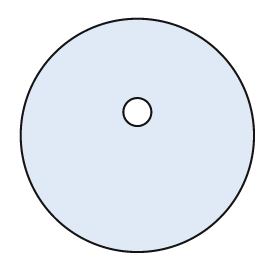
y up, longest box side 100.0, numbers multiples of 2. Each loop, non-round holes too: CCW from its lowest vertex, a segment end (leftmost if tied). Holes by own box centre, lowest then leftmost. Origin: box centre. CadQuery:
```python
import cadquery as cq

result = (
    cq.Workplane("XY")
    .moveTo(0.0, 0.0)
    .circle(50.0)
    .moveTo(0.0, 10.0)
    .circle(6.0)
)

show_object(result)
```